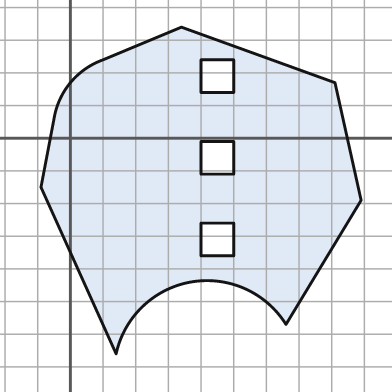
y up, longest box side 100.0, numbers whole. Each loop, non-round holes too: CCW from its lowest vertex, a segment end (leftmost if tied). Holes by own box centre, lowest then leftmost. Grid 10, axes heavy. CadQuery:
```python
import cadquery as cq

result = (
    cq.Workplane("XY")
    .moveTo(14.0, -66.0)
    .threePointArc((37.0, -44.0), (66.0, -57.0))
    .lineTo(89.0, -19.0)
    .lineTo(81.0, 17.0)
    .lineTo(34.0, 34.0)
    .lineTo(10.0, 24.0)
    .threePointArc((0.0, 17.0), (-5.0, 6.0))
    .lineTo(-9.0, -15.0)
    .close()
    .moveTo(40.0, -36.0)
    .lineTo(50.0, -36.0)
    .lineTo(50.0, -26.0)
    .lineTo(40.0, -26.0)
    .close()
    .moveTo(40.0, -11.0)
    .lineTo(50.0, -11.0)
    .lineTo(50.0, -1.0)
    .lineTo(40.0, -1.0)
    .close()
    .moveTo(40.0, 14.0)
    .lineTo(50.0, 14.0)
    .lineTo(50.0, 24.0)
    .lineTo(40.0, 24.0)
    .close()
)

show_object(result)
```